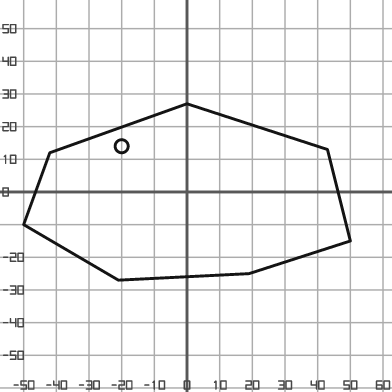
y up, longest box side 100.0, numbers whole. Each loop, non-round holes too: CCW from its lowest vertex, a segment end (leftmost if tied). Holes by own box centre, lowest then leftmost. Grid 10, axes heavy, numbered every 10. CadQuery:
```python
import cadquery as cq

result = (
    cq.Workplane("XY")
    .moveTo(-21.0, -27.0)
    .lineTo(19.0, -25.0)
    .lineTo(50.0, -15.0)
    .lineTo(43.0, 13.0)
    .lineTo(0.0, 27.0)
    .lineTo(-42.0, 12.0)
    .lineTo(-50.0, -10.0)
    .close()
    .moveTo(-20.0, 14.0)
    .circle(2.0)
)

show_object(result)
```